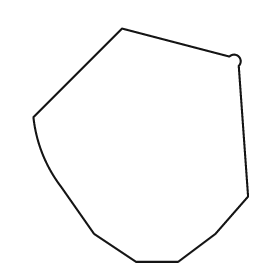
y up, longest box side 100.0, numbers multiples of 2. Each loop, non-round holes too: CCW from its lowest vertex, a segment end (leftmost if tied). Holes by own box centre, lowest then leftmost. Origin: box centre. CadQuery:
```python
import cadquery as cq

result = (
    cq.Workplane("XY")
    .moveTo(-2.0, -50.0)
    .lineTo(16.0, -50.0)
    .lineTo(32.0, -38.0)
    .lineTo(46.0, -22.0)
    .lineTo(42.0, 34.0)
    .threePointArc((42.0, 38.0), (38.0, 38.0))
    .lineTo(-8.0, 50.0)
    .lineTo(-46.0, 12.0)
    .threePointArc((-42.0, -4.0), (-34.0, -18.0))
    .lineTo(-20.0, -38.0)
    .close()
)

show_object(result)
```